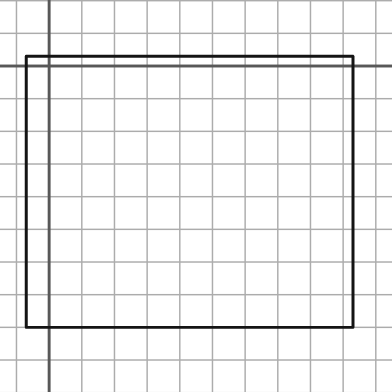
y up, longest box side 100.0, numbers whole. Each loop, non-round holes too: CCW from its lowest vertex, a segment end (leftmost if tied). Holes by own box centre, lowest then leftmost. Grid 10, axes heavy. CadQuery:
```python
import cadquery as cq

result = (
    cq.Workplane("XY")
    .moveTo(-7.0, -80.0)
    .lineTo(93.0, -80.0)
    .lineTo(93.0, 3.0)
    .lineTo(-7.0, 3.0)
    .close()
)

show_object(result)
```